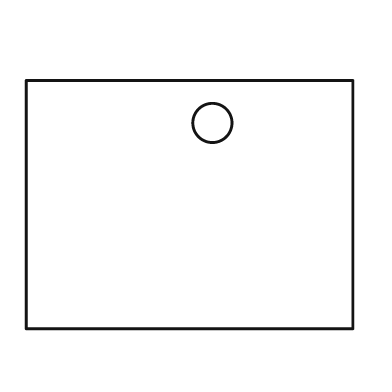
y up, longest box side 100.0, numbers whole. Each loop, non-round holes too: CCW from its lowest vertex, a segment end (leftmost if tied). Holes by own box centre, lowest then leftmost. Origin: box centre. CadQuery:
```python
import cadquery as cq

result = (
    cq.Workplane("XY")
    .moveTo(-50.0, -38.0)
    .lineTo(50.0, -38.0)
    .lineTo(50.0, 38.0)
    .lineTo(-50.0, 38.0)
    .close()
    .moveTo(7.0, 25.0)
    .circle(6.0)
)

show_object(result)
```